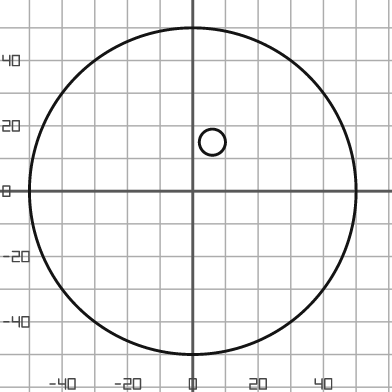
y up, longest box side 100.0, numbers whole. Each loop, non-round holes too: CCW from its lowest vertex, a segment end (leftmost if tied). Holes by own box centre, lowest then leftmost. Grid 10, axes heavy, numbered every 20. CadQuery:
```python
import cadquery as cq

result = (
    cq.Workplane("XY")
    .moveTo(0.0, 0.0)
    .circle(50.0)
    .moveTo(6.0, 15.0)
    .circle(4.0)
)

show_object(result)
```